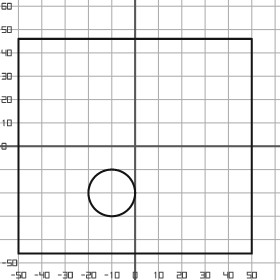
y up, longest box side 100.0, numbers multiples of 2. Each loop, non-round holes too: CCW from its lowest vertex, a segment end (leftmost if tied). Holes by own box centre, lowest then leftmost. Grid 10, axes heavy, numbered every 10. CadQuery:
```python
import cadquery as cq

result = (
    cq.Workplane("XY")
    .moveTo(-50.0, -46.0)
    .lineTo(50.0, -46.0)
    .lineTo(50.0, 46.0)
    .lineTo(-50.0, 46.0)
    .close()
    .moveTo(-10.0, -20.0)
    .circle(10.0)
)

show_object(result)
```